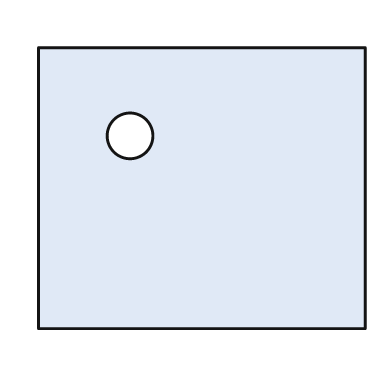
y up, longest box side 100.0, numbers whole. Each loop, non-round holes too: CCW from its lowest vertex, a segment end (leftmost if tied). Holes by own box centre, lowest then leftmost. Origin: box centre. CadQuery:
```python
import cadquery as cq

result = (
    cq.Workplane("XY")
    .moveTo(-50.0, -43.0)
    .lineTo(50.0, -43.0)
    .lineTo(50.0, 43.0)
    .lineTo(-50.0, 43.0)
    .close()
    .moveTo(-22.0, 16.0)
    .circle(7.0)
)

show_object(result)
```